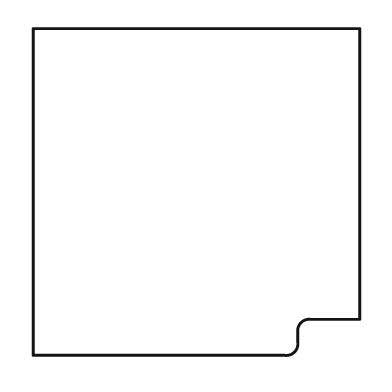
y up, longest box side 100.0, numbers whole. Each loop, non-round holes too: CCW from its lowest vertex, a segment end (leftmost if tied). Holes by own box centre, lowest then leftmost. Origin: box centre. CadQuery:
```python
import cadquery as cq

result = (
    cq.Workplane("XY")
    .moveTo(-50.0, -50.0)
    .lineTo(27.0, -50.0)
    .threePointArc((30.0, -49.0), (31.0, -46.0))
    .lineTo(31.0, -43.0)
    .threePointArc((32.0, -40.0), (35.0, -39.0))
    .lineTo(50.0, -39.0)
    .lineTo(50.0, 50.0)
    .lineTo(-50.0, 50.0)
    .close()
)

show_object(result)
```